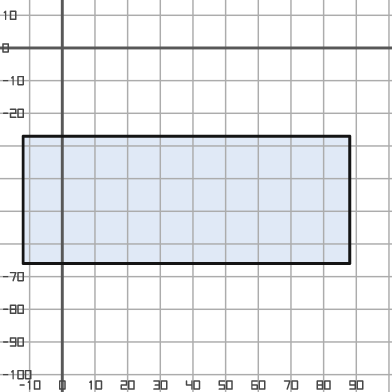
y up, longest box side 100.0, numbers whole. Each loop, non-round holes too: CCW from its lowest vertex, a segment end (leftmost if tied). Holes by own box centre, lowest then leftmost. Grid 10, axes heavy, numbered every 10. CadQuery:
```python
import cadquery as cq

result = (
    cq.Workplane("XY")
    .moveTo(-12.0, -66.0)
    .lineTo(88.0, -66.0)
    .lineTo(88.0, -27.0)
    .lineTo(-12.0, -27.0)
    .close()
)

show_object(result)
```